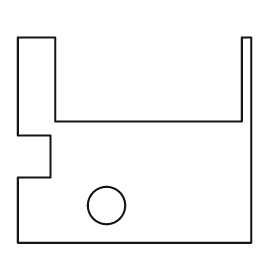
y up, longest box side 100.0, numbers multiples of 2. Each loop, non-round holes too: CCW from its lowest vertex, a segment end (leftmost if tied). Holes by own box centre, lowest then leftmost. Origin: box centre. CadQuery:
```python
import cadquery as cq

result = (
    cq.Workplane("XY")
    .moveTo(-50.0, -44.0)
    .lineTo(50.0, -44.0)
    .lineTo(50.0, 44.0)
    .lineTo(46.0, 44.0)
    .lineTo(46.0, 8.0)
    .lineTo(-34.0, 8.0)
    .lineTo(-34.0, 44.0)
    .lineTo(-50.0, 44.0)
    .lineTo(-50.0, 2.0)
    .lineTo(-36.0, 2.0)
    .lineTo(-36.0, -16.0)
    .lineTo(-50.0, -16.0)
    .close()
    .moveTo(-12.0, -28.0)
    .circle(8.0)
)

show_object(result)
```